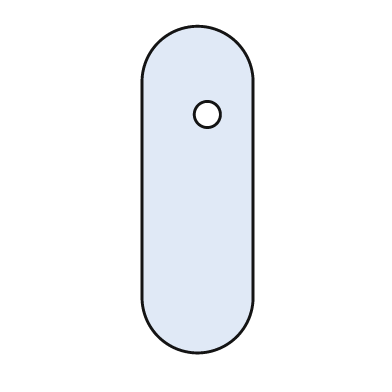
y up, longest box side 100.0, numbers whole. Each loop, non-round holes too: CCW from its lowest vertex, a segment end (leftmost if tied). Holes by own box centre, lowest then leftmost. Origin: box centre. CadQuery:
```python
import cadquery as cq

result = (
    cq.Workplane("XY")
    .moveTo(-17.0, -33.0)
    .threePointArc((0.0, -50.0), (17.0, -33.0))
    .lineTo(17.0, 33.0)
    .threePointArc((0.0, 50.0), (-17.0, 33.0))
    .close()
    .moveTo(3.0, 23.0)
    .circle(4.0)
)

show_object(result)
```